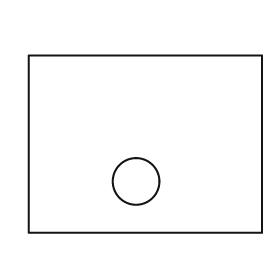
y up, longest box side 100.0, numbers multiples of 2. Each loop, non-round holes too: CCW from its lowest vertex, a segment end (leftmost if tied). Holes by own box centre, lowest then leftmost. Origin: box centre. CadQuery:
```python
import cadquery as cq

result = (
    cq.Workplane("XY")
    .moveTo(-50.0, -38.0)
    .lineTo(50.0, -38.0)
    .lineTo(50.0, 38.0)
    .lineTo(-50.0, 38.0)
    .close()
    .moveTo(-4.0, -16.0)
    .circle(10.0)
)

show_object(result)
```